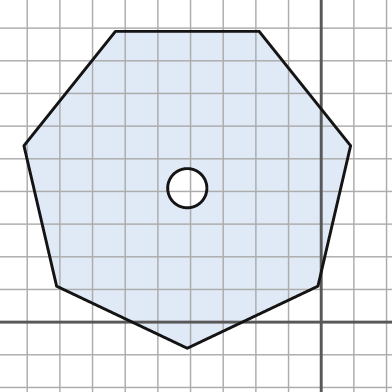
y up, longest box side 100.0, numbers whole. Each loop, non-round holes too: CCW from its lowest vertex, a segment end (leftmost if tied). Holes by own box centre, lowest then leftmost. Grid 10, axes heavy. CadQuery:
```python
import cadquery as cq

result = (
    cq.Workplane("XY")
    .moveTo(-41.0, -8.0)
    .lineTo(-1.0, 11.0)
    .lineTo(9.0, 54.0)
    .lineTo(-19.0, 89.0)
    .lineTo(-63.0, 89.0)
    .lineTo(-91.0, 54.0)
    .lineTo(-81.0, 11.0)
    .close()
    .moveTo(-41.0, 41.0)
    .circle(6.0)
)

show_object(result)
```